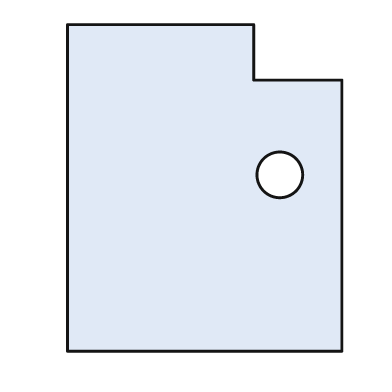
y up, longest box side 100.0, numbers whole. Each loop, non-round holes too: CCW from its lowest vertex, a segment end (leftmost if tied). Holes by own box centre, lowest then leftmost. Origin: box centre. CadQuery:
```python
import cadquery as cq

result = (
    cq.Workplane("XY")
    .moveTo(-42.0, -50.0)
    .lineTo(42.0, -50.0)
    .lineTo(42.0, 33.0)
    .lineTo(15.0, 33.0)
    .lineTo(15.0, 50.0)
    .lineTo(-42.0, 50.0)
    .close()
    .moveTo(23.0, 4.0)
    .circle(7.0)
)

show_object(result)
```